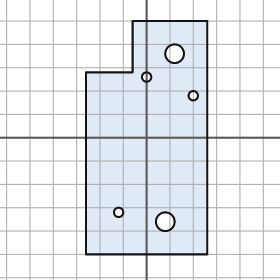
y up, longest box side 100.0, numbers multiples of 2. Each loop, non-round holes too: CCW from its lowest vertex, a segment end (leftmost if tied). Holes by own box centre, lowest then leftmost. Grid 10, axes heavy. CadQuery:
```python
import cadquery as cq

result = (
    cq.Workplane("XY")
    .moveTo(-26.0, -50.0)
    .lineTo(26.0, -50.0)
    .lineTo(26.0, 50.0)
    .lineTo(-6.0, 50.0)
    .lineTo(-6.0, 28.0)
    .lineTo(-26.0, 28.0)
    .close()
    .moveTo(8.0, -36.0)
    .circle(4.0)
    .moveTo(-12.0, -32.0)
    .circle(2.0)
    .moveTo(20.0, 18.0)
    .circle(2.0)
    .moveTo(0.0, 26.0)
    .circle(2.0)
    .moveTo(12.0, 36.0)
    .circle(4.0)
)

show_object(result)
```